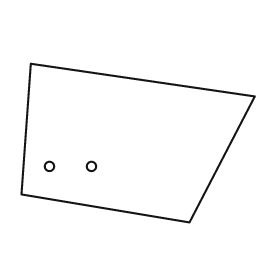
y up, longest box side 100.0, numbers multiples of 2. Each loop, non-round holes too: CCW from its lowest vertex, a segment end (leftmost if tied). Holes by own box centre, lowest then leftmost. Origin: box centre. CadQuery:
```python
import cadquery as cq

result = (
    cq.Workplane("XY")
    .moveTo(22.0, -34.0)
    .lineTo(50.0, 20.0)
    .lineTo(-46.0, 34.0)
    .lineTo(-50.0, -22.0)
    .close()
    .moveTo(-38.0, -10.0)
    .circle(2.0)
    .moveTo(-20.0, -10.0)
    .circle(2.0)
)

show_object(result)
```